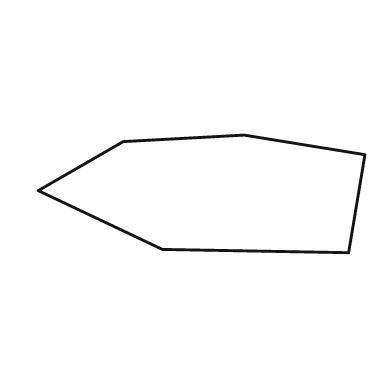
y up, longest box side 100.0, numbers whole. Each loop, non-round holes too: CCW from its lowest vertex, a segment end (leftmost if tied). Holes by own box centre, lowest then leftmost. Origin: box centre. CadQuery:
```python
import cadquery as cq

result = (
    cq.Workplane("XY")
    .moveTo(45.0, -18.0)
    .lineTo(50.0, 12.0)
    .lineTo(13.0, 18.0)
    .lineTo(-24.0, 16.0)
    .lineTo(-50.0, 1.0)
    .lineTo(-12.0, -17.0)
    .close()
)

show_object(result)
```